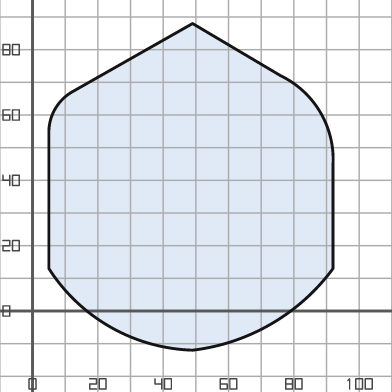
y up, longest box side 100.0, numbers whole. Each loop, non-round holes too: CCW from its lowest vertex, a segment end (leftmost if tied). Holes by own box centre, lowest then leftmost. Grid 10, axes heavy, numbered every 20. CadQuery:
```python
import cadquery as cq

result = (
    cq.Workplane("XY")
    .moveTo(49.0, -12.0)
    .threePointArc((73.0, -4.0), (92.0, 13.0))
    .lineTo(92.0, 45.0)
    .threePointArc((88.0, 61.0), (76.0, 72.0))
    .lineTo(49.0, 88.0)
    .lineTo(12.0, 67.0)
    .threePointArc((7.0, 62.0), (5.0, 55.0))
    .lineTo(5.0, 13.0)
    .threePointArc((24.0, -5.0), (49.0, -12.0))
    .close()
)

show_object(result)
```